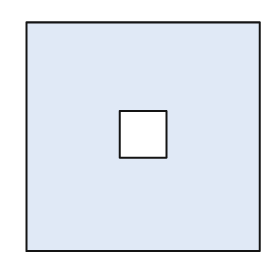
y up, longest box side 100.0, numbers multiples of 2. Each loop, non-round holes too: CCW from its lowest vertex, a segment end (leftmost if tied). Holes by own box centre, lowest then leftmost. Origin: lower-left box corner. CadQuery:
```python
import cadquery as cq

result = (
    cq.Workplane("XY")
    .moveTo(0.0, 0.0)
    .lineTo(100.0, 0.0)
    .lineTo(100.0, 98.0)
    .lineTo(0.0, 98.0)
    .close()
    .moveTo(40.0, 40.0)
    .lineTo(60.0, 40.0)
    .lineTo(60.0, 60.0)
    .lineTo(40.0, 60.0)
    .close()
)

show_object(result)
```